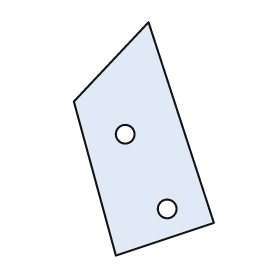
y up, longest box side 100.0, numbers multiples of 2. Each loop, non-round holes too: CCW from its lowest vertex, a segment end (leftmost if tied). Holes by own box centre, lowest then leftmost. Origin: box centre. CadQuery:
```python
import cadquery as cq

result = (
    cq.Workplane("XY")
    .moveTo(-12.0, -50.0)
    .lineTo(30.0, -36.0)
    .lineTo(2.0, 50.0)
    .lineTo(-30.0, 16.0)
    .close()
    .moveTo(10.0, -30.0)
    .circle(4.0)
    .moveTo(-8.0, 2.0)
    .circle(4.0)
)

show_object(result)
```